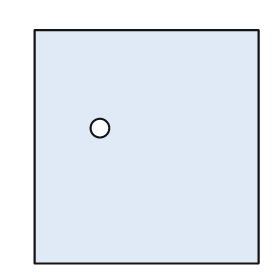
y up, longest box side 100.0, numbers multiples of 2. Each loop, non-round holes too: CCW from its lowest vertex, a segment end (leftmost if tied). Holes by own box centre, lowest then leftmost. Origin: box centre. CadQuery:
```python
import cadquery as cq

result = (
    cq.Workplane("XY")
    .moveTo(-48.0, -50.0)
    .lineTo(48.0, -50.0)
    .lineTo(48.0, 50.0)
    .lineTo(-48.0, 50.0)
    .close()
    .moveTo(-20.0, 8.0)
    .circle(4.0)
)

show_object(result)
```